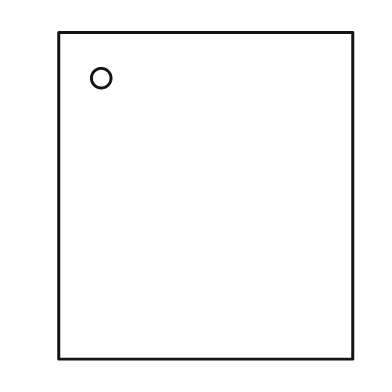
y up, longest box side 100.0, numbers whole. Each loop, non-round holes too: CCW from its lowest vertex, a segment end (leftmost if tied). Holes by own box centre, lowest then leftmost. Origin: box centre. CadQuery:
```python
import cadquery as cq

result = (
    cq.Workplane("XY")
    .moveTo(-45.0, -50.0)
    .lineTo(45.0, -50.0)
    .lineTo(45.0, 50.0)
    .lineTo(-45.0, 50.0)
    .close()
    .moveTo(-32.0, 36.0)
    .circle(3.0)
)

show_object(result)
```